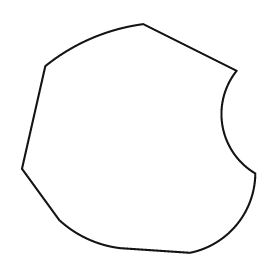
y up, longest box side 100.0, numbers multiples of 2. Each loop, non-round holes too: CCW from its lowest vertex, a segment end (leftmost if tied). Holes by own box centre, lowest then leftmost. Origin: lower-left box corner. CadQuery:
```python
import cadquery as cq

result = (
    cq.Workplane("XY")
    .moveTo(72.0, 0.0)
    .threePointArc((92.0, 12.0), (100.0, 34.0))
    .threePointArc((86.0, 54.0), (92.0, 78.0))
    .lineTo(52.0, 98.0)
    .threePointArc((30.0, 92.0), (10.0, 80.0))
    .lineTo(0.0, 36.0)
    .lineTo(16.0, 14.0)
    .threePointArc((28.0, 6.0), (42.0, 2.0))
    .close()
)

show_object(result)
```